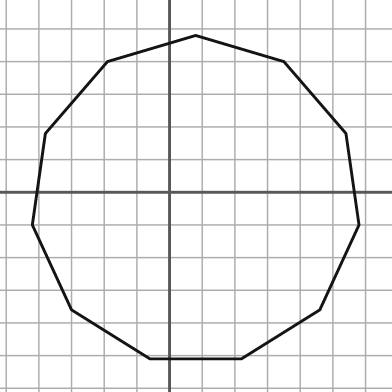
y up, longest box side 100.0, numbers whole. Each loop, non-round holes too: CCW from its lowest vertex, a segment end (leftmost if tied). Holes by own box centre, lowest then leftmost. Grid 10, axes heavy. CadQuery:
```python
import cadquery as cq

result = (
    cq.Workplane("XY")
    .moveTo(-6.0, -51.0)
    .lineTo(22.0, -51.0)
    .lineTo(46.0, -36.0)
    .lineTo(58.0, -10.0)
    .lineTo(54.0, 18.0)
    .lineTo(35.0, 40.0)
    .lineTo(8.0, 48.0)
    .lineTo(-19.0, 40.0)
    .lineTo(-38.0, 18.0)
    .lineTo(-42.0, -10.0)
    .lineTo(-30.0, -36.0)
    .close()
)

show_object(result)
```